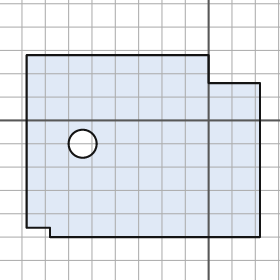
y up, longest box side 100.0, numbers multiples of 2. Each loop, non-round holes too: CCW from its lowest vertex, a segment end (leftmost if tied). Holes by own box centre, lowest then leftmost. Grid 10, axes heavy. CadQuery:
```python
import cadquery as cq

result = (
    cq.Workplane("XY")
    .moveTo(-68.0, -50.0)
    .lineTo(22.0, -50.0)
    .lineTo(22.0, 16.0)
    .lineTo(0.0, 16.0)
    .lineTo(0.0, 28.0)
    .lineTo(-78.0, 28.0)
    .lineTo(-78.0, -46.0)
    .lineTo(-68.0, -46.0)
    .close()
    .moveTo(-54.0, -10.0)
    .circle(6.0)
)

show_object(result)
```